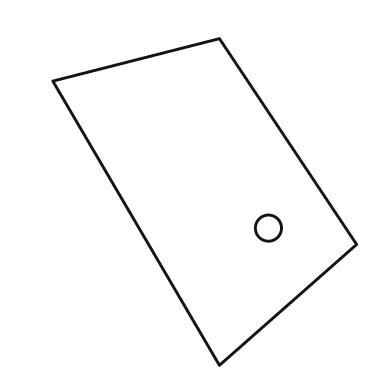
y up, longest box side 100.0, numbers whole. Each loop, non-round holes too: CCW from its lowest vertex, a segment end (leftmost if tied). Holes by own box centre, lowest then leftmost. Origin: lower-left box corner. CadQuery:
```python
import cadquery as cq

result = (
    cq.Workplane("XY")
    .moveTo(51.0, 0.0)
    .lineTo(93.0, 37.0)
    .lineTo(51.0, 100.0)
    .lineTo(0.0, 87.0)
    .close()
    .moveTo(66.0, 42.0)
    .circle(4.0)
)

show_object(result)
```